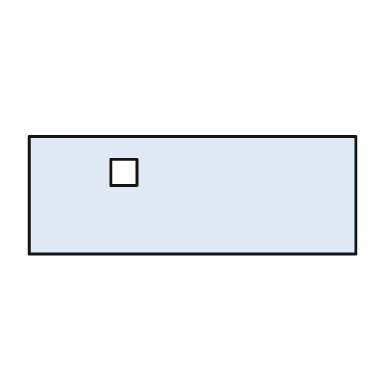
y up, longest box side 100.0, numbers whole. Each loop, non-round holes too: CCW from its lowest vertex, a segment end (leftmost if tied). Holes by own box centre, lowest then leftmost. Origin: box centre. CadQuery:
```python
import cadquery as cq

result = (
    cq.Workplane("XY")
    .moveTo(-50.0, -18.0)
    .lineTo(50.0, -18.0)
    .lineTo(50.0, 18.0)
    .lineTo(-50.0, 18.0)
    .close()
    .moveTo(-25.0, 3.0)
    .lineTo(-17.0, 3.0)
    .lineTo(-17.0, 11.0)
    .lineTo(-25.0, 11.0)
    .close()
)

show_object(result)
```